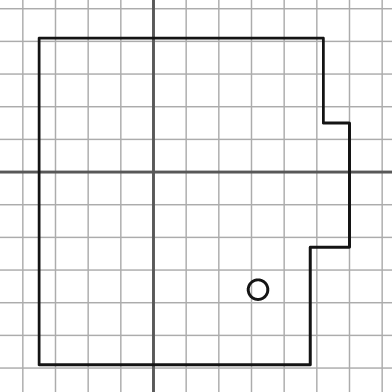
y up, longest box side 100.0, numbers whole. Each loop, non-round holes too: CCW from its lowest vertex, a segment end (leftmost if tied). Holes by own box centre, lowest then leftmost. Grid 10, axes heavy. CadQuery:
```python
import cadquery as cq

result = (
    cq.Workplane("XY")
    .moveTo(-35.0, -59.0)
    .lineTo(48.0, -59.0)
    .lineTo(48.0, -23.0)
    .lineTo(60.0, -23.0)
    .lineTo(60.0, 15.0)
    .lineTo(52.0, 15.0)
    .lineTo(52.0, 41.0)
    .lineTo(-35.0, 41.0)
    .close()
    .moveTo(32.0, -36.0)
    .circle(3.0)
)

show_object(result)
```